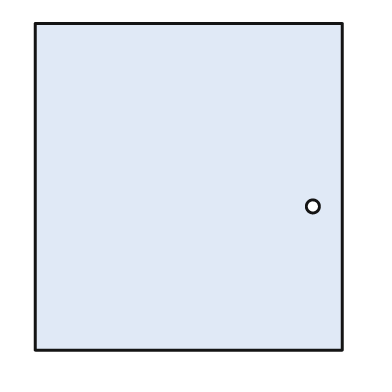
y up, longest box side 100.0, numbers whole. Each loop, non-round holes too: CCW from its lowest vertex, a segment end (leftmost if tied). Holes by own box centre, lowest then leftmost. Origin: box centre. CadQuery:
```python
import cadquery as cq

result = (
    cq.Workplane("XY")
    .moveTo(-47.0, -50.0)
    .lineTo(47.0, -50.0)
    .lineTo(47.0, 50.0)
    .lineTo(-47.0, 50.0)
    .close()
    .moveTo(38.0, -6.0)
    .circle(2.0)
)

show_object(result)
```